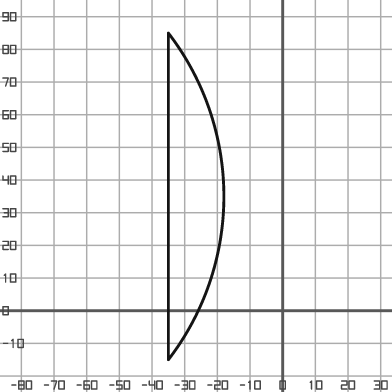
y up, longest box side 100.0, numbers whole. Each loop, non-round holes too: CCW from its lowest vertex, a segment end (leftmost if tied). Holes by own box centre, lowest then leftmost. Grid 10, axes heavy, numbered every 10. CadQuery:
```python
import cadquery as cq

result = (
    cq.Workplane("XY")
    .moveTo(-35.0, -15.0)
    .threePointArc((-18.0, 35.0), (-35.0, 85.0))
    .close()
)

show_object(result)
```